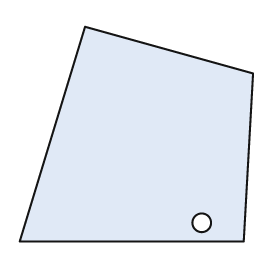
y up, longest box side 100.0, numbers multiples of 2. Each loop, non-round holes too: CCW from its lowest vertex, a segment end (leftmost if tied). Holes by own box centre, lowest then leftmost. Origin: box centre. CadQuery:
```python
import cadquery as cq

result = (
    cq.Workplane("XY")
    .moveTo(-50.0, -46.0)
    .lineTo(46.0, -46.0)
    .lineTo(50.0, 26.0)
    .lineTo(-22.0, 46.0)
    .close()
    .moveTo(28.0, -38.0)
    .circle(4.0)
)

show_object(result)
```